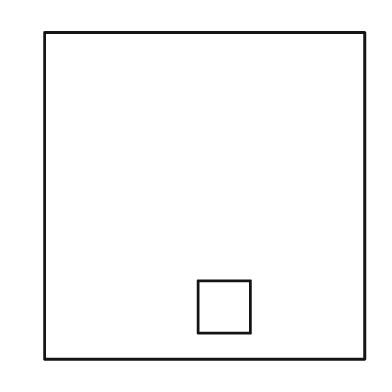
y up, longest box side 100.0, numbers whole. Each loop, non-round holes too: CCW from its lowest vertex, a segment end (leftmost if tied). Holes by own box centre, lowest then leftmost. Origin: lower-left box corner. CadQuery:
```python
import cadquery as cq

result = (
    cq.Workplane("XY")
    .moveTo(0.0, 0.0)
    .lineTo(98.0, 0.0)
    .lineTo(98.0, 100.0)
    .lineTo(0.0, 100.0)
    .close()
    .moveTo(47.0, 8.0)
    .lineTo(63.0, 8.0)
    .lineTo(63.0, 24.0)
    .lineTo(47.0, 24.0)
    .close()
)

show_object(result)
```